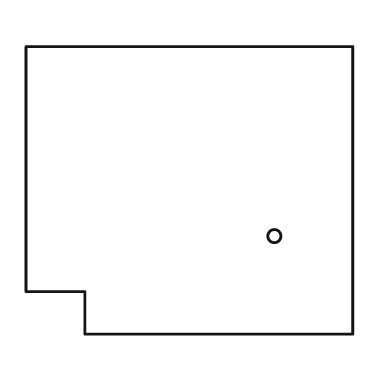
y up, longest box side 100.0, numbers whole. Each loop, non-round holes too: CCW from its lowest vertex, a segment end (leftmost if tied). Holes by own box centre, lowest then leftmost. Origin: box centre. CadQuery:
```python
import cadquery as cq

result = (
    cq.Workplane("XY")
    .moveTo(-32.0, -44.0)
    .lineTo(50.0, -44.0)
    .lineTo(50.0, 44.0)
    .lineTo(-50.0, 44.0)
    .lineTo(-50.0, -31.0)
    .lineTo(-32.0, -31.0)
    .close()
    .moveTo(26.0, -14.0)
    .circle(2.0)
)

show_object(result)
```